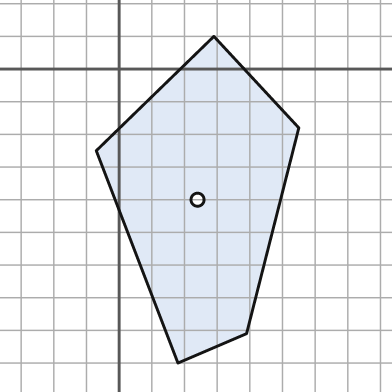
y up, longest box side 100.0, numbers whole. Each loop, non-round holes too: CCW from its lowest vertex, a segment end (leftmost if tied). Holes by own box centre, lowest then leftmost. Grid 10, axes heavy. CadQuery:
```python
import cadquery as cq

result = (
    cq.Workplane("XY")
    .moveTo(18.0, -90.0)
    .lineTo(39.0, -81.0)
    .lineTo(55.0, -18.0)
    .lineTo(29.0, 10.0)
    .lineTo(-7.0, -25.0)
    .close()
    .moveTo(24.0, -40.0)
    .circle(2.0)
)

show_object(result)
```